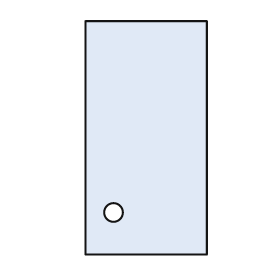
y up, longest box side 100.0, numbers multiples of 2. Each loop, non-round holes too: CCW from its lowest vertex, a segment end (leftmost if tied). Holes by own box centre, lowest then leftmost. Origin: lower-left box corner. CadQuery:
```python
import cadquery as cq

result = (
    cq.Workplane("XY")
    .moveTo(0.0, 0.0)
    .lineTo(52.0, 0.0)
    .lineTo(52.0, 100.0)
    .lineTo(0.0, 100.0)
    .close()
    .moveTo(12.0, 18.0)
    .circle(4.0)
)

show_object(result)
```